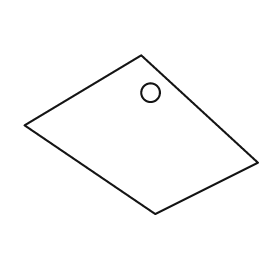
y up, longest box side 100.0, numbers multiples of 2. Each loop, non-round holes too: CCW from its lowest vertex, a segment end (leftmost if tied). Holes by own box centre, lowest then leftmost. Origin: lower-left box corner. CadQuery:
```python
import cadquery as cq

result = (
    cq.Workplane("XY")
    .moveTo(56.0, 0.0)
    .lineTo(100.0, 22.0)
    .lineTo(50.0, 68.0)
    .lineTo(0.0, 38.0)
    .close()
    .moveTo(54.0, 52.0)
    .circle(4.0)
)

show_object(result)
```